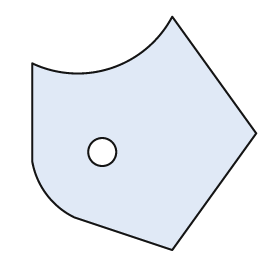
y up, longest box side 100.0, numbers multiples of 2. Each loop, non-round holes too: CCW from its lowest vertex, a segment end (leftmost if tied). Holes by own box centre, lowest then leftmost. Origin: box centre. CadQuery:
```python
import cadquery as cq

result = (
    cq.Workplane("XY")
    .moveTo(12.0, -50.0)
    .lineTo(48.0, 0.0)
    .lineTo(12.0, 50.0)
    .threePointArc((-14.0, 28.0), (-48.0, 30.0))
    .lineTo(-48.0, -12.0)
    .threePointArc((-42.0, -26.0), (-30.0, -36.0))
    .close()
    .moveTo(-18.0, -8.0)
    .circle(6.0)
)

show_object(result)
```